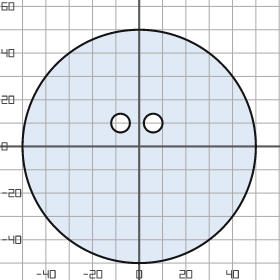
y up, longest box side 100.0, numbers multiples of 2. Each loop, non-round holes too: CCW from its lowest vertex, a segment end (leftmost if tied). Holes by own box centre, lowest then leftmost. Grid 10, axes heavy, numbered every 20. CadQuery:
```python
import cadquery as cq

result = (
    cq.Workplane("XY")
    .moveTo(0.0, 0.0)
    .circle(50.0)
    .moveTo(-8.0, 10.0)
    .circle(4.0)
    .moveTo(6.0, 10.0)
    .circle(4.0)
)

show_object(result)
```